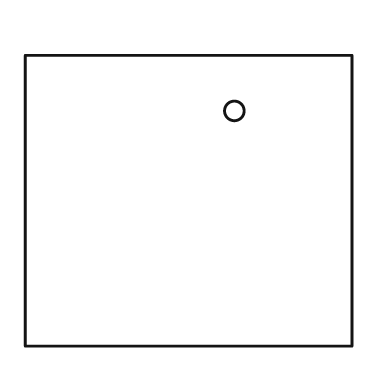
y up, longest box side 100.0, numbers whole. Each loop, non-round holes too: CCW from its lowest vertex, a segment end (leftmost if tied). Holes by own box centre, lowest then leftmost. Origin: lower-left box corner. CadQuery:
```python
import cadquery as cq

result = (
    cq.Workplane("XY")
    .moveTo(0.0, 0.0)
    .lineTo(100.0, 0.0)
    .lineTo(100.0, 89.0)
    .lineTo(0.0, 89.0)
    .close()
    .moveTo(64.0, 72.0)
    .circle(3.0)
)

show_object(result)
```